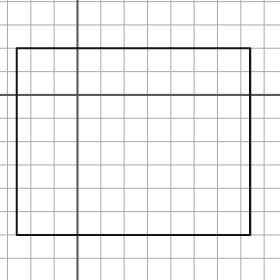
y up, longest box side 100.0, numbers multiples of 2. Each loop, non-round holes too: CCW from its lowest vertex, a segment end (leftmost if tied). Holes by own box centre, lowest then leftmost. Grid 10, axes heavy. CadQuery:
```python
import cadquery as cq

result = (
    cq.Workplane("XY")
    .moveTo(-26.0, -60.0)
    .lineTo(74.0, -60.0)
    .lineTo(74.0, 20.0)
    .lineTo(-26.0, 20.0)
    .close()
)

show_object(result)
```